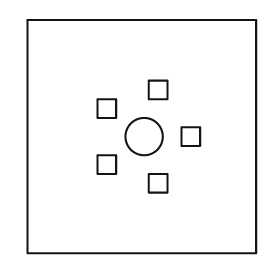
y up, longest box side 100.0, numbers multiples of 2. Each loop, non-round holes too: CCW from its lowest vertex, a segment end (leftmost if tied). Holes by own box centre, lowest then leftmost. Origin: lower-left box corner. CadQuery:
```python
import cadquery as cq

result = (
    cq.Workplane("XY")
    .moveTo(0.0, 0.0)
    .lineTo(98.0, 0.0)
    .lineTo(98.0, 100.0)
    .lineTo(0.0, 100.0)
    .close()
    .moveTo(52.0, 26.0)
    .lineTo(60.0, 26.0)
    .lineTo(60.0, 34.0)
    .lineTo(52.0, 34.0)
    .close()
    .moveTo(30.0, 34.0)
    .lineTo(38.0, 34.0)
    .lineTo(38.0, 42.0)
    .lineTo(30.0, 42.0)
    .close()
    .moveTo(50.0, 50.0)
    .circle(8.0)
    .moveTo(66.0, 46.0)
    .lineTo(74.0, 46.0)
    .lineTo(74.0, 54.0)
    .lineTo(66.0, 54.0)
    .close()
    .moveTo(30.0, 58.0)
    .lineTo(38.0, 58.0)
    .lineTo(38.0, 66.0)
    .lineTo(30.0, 66.0)
    .close()
    .moveTo(52.0, 66.0)
    .lineTo(60.0, 66.0)
    .lineTo(60.0, 74.0)
    .lineTo(52.0, 74.0)
    .close()
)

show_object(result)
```